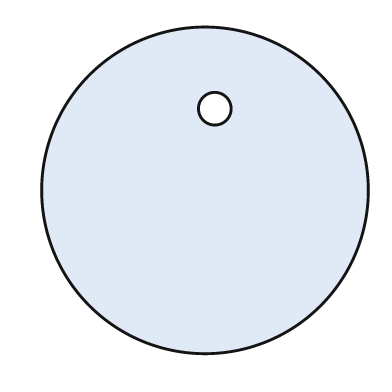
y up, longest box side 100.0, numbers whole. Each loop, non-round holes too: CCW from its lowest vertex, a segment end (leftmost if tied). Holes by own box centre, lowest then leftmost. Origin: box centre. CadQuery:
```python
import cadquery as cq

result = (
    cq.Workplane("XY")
    .moveTo(0.0, 0.0)
    .circle(50.0)
    .moveTo(3.0, 25.0)
    .circle(5.0)
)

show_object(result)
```